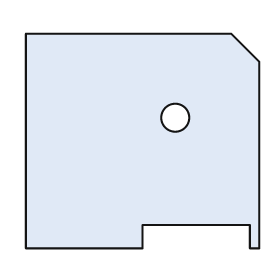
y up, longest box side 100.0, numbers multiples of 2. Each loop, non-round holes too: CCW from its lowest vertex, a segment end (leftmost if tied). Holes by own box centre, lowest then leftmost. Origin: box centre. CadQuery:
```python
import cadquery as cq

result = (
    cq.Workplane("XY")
    .moveTo(-50.0, -46.0)
    .lineTo(0.0, -46.0)
    .lineTo(0.0, -36.0)
    .lineTo(46.0, -36.0)
    .lineTo(46.0, -46.0)
    .lineTo(50.0, -46.0)
    .lineTo(50.0, 34.0)
    .lineTo(38.0, 46.0)
    .lineTo(-50.0, 46.0)
    .close()
    .moveTo(14.0, 10.0)
    .circle(6.0)
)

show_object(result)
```